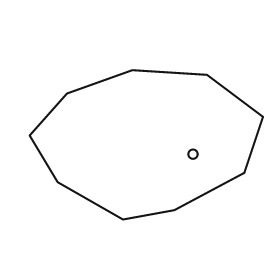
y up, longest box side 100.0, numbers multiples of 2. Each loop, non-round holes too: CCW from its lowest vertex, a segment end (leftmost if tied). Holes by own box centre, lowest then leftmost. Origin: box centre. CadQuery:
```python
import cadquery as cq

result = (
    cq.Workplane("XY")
    .moveTo(-10.0, -32.0)
    .lineTo(12.0, -28.0)
    .lineTo(42.0, -12.0)
    .lineTo(50.0, 12.0)
    .lineTo(26.0, 30.0)
    .lineTo(-6.0, 32.0)
    .lineTo(-34.0, 22.0)
    .lineTo(-50.0, 4.0)
    .lineTo(-38.0, -16.0)
    .close()
    .moveTo(20.0, -4.0)
    .circle(2.0)
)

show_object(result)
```